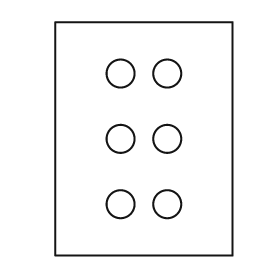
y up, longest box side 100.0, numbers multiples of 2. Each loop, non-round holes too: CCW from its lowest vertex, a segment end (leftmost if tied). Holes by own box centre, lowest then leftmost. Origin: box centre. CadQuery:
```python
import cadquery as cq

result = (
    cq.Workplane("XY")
    .moveTo(-38.0, -50.0)
    .lineTo(38.0, -50.0)
    .lineTo(38.0, 50.0)
    .lineTo(-38.0, 50.0)
    .close()
    .moveTo(-10.0, -28.0)
    .circle(6.0)
    .moveTo(10.0, -28.0)
    .circle(6.0)
    .moveTo(-10.0, 0.0)
    .circle(6.0)
    .moveTo(10.0, 0.0)
    .circle(6.0)
    .moveTo(-10.0, 28.0)
    .circle(6.0)
    .moveTo(10.0, 28.0)
    .circle(6.0)
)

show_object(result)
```